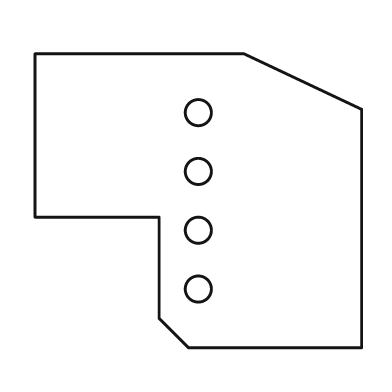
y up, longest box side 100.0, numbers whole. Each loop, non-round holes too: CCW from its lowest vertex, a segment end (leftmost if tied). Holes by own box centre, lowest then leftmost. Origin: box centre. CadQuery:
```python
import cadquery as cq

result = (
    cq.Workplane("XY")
    .moveTo(-3.0, -45.0)
    .lineTo(50.0, -45.0)
    .lineTo(50.0, 28.0)
    .lineTo(14.0, 45.0)
    .lineTo(-50.0, 45.0)
    .lineTo(-50.0, -5.0)
    .lineTo(-12.0, -5.0)
    .lineTo(-12.0, -36.0)
    .close()
    .moveTo(0.0, -27.0)
    .circle(4.0)
    .moveTo(0.0, -9.0)
    .circle(4.0)
    .moveTo(0.0, 9.0)
    .circle(4.0)
    .moveTo(0.0, 27.0)
    .circle(4.0)
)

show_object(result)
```